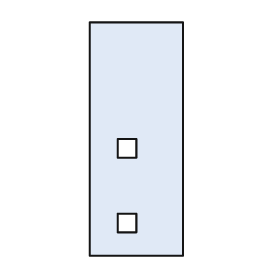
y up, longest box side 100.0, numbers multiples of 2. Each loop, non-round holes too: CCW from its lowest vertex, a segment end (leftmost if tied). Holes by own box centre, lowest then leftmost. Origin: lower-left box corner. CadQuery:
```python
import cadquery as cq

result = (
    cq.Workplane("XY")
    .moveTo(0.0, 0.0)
    .lineTo(40.0, 0.0)
    .lineTo(40.0, 100.0)
    .lineTo(0.0, 100.0)
    .close()
    .moveTo(12.0, 10.0)
    .lineTo(20.0, 10.0)
    .lineTo(20.0, 18.0)
    .lineTo(12.0, 18.0)
    .close()
    .moveTo(12.0, 42.0)
    .lineTo(20.0, 42.0)
    .lineTo(20.0, 50.0)
    .lineTo(12.0, 50.0)
    .close()
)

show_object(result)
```